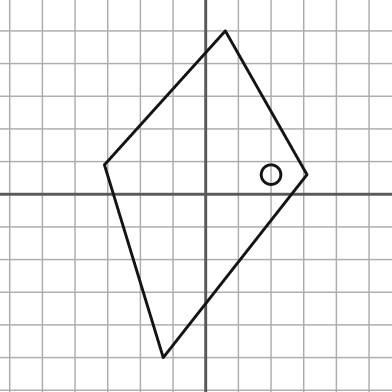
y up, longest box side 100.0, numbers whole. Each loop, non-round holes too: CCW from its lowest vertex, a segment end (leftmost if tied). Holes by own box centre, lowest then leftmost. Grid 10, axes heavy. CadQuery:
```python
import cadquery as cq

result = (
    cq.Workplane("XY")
    .moveTo(-13.0, -50.0)
    .lineTo(31.0, 6.0)
    .lineTo(6.0, 50.0)
    .lineTo(-31.0, 9.0)
    .close()
    .moveTo(20.0, 6.0)
    .circle(3.0)
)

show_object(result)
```